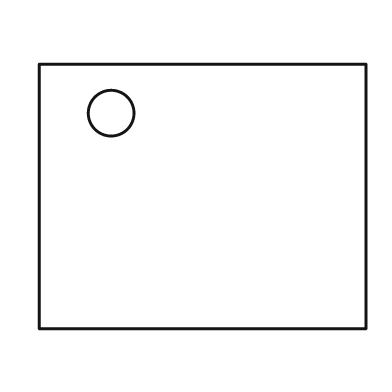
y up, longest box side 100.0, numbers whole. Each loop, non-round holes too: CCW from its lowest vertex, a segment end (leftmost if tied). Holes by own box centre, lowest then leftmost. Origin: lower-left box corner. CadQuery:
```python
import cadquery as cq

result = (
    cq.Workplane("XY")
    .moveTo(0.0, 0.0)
    .lineTo(100.0, 0.0)
    .lineTo(100.0, 81.0)
    .lineTo(0.0, 81.0)
    .close()
    .moveTo(22.0, 66.0)
    .circle(7.0)
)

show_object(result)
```